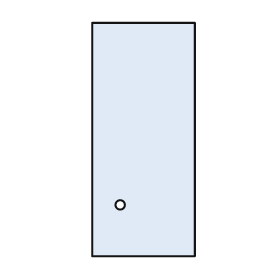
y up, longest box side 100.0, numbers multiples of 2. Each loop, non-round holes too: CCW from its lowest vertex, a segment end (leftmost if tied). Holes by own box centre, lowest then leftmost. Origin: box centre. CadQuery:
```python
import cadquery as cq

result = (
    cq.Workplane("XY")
    .moveTo(-22.0, -50.0)
    .lineTo(22.0, -50.0)
    .lineTo(22.0, 50.0)
    .lineTo(-22.0, 50.0)
    .close()
    .moveTo(-10.0, -28.0)
    .circle(2.0)
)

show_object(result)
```